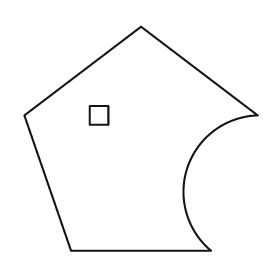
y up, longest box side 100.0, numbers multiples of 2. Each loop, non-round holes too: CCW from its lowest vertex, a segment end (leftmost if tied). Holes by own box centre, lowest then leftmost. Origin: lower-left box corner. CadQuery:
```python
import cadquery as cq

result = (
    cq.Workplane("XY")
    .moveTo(20.0, 0.0)
    .lineTo(80.0, 0.0)
    .threePointArc((70.0, 36.0), (100.0, 58.0))
    .lineTo(50.0, 96.0)
    .lineTo(0.0, 58.0)
    .close()
    .moveTo(28.0, 54.0)
    .lineTo(36.0, 54.0)
    .lineTo(36.0, 62.0)
    .lineTo(28.0, 62.0)
    .close()
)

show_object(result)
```